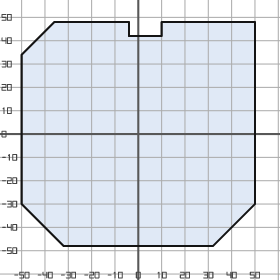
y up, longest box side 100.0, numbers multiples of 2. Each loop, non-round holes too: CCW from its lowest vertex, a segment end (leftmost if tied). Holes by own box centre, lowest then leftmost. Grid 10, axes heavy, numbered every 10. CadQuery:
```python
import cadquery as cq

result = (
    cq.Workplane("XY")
    .moveTo(-32.0, -48.0)
    .lineTo(32.0, -48.0)
    .lineTo(50.0, -30.0)
    .lineTo(50.0, 48.0)
    .lineTo(10.0, 48.0)
    .lineTo(10.0, 42.0)
    .lineTo(-4.0, 42.0)
    .lineTo(-4.0, 48.0)
    .lineTo(-36.0, 48.0)
    .lineTo(-50.0, 34.0)
    .lineTo(-50.0, -30.0)
    .close()
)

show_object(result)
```